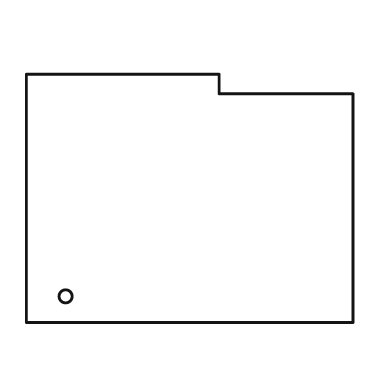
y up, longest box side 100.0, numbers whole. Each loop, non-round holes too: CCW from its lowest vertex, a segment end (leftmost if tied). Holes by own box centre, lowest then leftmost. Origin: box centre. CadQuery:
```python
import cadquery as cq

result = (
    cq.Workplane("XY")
    .moveTo(-50.0, -38.0)
    .lineTo(50.0, -38.0)
    .lineTo(50.0, 32.0)
    .lineTo(9.0, 32.0)
    .lineTo(9.0, 38.0)
    .lineTo(-50.0, 38.0)
    .close()
    .moveTo(-38.0, -30.0)
    .circle(2.0)
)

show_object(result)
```